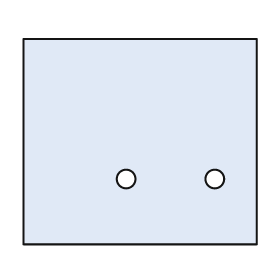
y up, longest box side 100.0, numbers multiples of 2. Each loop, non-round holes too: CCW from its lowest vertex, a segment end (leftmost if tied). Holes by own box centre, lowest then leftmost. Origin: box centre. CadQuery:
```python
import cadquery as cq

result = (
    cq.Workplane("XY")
    .moveTo(-50.0, -44.0)
    .lineTo(50.0, -44.0)
    .lineTo(50.0, 44.0)
    .lineTo(-50.0, 44.0)
    .close()
    .moveTo(-6.0, -16.0)
    .circle(4.0)
    .moveTo(32.0, -16.0)
    .circle(4.0)
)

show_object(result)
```